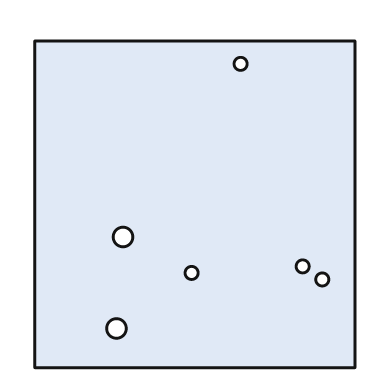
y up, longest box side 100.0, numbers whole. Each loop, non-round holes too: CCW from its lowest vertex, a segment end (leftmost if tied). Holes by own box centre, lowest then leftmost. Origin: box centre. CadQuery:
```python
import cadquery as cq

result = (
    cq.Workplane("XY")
    .moveTo(-49.0, -50.0)
    .lineTo(49.0, -50.0)
    .lineTo(49.0, 50.0)
    .lineTo(-49.0, 50.0)
    .close()
    .moveTo(-24.0, -38.0)
    .circle(3.0)
    .moveTo(39.0, -23.0)
    .circle(2.0)
    .moveTo(-1.0, -21.0)
    .circle(2.0)
    .moveTo(33.0, -19.0)
    .circle(2.0)
    .moveTo(-22.0, -10.0)
    .circle(3.0)
    .moveTo(14.0, 43.0)
    .circle(2.0)
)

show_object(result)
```